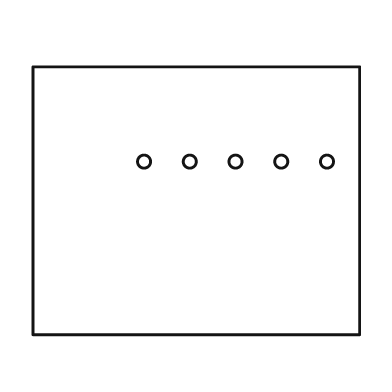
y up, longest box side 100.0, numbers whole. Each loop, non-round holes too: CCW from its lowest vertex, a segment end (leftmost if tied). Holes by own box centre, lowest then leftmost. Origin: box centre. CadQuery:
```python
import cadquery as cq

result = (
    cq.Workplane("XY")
    .moveTo(-50.0, -41.0)
    .lineTo(50.0, -41.0)
    .lineTo(50.0, 41.0)
    .lineTo(-50.0, 41.0)
    .close()
    .moveTo(-16.0, 12.0)
    .circle(2.0)
    .moveTo(-2.0, 12.0)
    .circle(2.0)
    .moveTo(12.0, 12.0)
    .circle(2.0)
    .moveTo(26.0, 12.0)
    .circle(2.0)
    .moveTo(40.0, 12.0)
    .circle(2.0)
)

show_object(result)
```